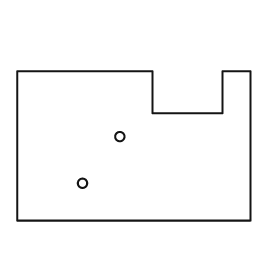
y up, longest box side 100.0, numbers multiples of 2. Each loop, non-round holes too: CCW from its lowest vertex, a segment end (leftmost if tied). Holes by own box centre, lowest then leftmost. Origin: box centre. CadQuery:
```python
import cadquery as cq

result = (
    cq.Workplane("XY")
    .moveTo(-50.0, -32.0)
    .lineTo(50.0, -32.0)
    .lineTo(50.0, 32.0)
    .lineTo(38.0, 32.0)
    .lineTo(38.0, 14.0)
    .lineTo(8.0, 14.0)
    .lineTo(8.0, 32.0)
    .lineTo(-50.0, 32.0)
    .close()
    .moveTo(-22.0, -16.0)
    .circle(2.0)
    .moveTo(-6.0, 4.0)
    .circle(2.0)
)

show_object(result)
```